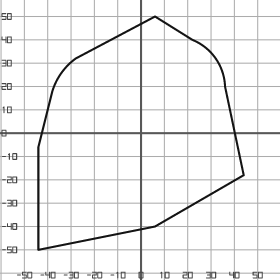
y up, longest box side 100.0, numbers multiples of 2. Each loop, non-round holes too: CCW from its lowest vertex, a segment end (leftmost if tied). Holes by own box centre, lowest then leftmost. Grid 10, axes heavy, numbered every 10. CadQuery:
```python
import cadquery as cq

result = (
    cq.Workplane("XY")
    .moveTo(-44.0, -50.0)
    .lineTo(6.0, -40.0)
    .lineTo(44.0, -18.0)
    .lineTo(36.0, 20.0)
    .threePointArc((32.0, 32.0), (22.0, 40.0))
    .lineTo(6.0, 50.0)
    .lineTo(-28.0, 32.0)
    .threePointArc((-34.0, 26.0), (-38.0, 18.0))
    .lineTo(-44.0, -6.0)
    .close()
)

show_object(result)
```